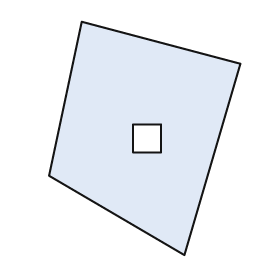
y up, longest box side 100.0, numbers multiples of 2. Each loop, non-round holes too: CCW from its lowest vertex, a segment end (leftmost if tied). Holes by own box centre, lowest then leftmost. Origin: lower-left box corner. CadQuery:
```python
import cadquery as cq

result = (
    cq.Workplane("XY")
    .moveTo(58.0, 0.0)
    .lineTo(82.0, 82.0)
    .lineTo(14.0, 100.0)
    .lineTo(0.0, 34.0)
    .close()
    .moveTo(36.0, 44.0)
    .lineTo(48.0, 44.0)
    .lineTo(48.0, 56.0)
    .lineTo(36.0, 56.0)
    .close()
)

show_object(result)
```